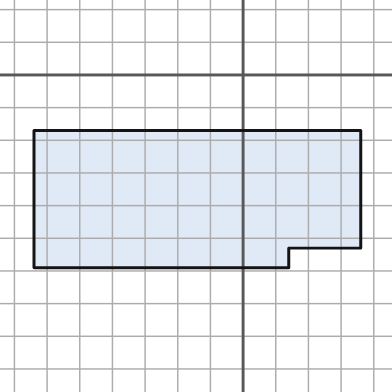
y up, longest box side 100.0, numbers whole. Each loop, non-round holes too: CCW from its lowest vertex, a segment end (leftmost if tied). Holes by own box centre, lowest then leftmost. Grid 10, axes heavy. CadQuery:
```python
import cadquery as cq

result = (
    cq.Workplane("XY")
    .moveTo(-64.0, -59.0)
    .lineTo(14.0, -59.0)
    .lineTo(14.0, -53.0)
    .lineTo(36.0, -53.0)
    .lineTo(36.0, -17.0)
    .lineTo(-64.0, -17.0)
    .close()
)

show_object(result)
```